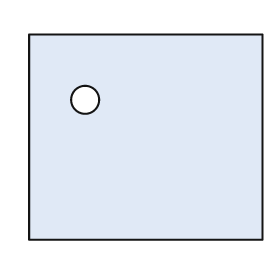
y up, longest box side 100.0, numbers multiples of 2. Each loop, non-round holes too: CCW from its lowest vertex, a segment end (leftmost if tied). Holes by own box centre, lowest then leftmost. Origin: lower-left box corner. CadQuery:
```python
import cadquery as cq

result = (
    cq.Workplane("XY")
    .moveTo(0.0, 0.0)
    .lineTo(100.0, 0.0)
    .lineTo(100.0, 88.0)
    .lineTo(0.0, 88.0)
    .close()
    .moveTo(24.0, 60.0)
    .circle(6.0)
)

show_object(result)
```